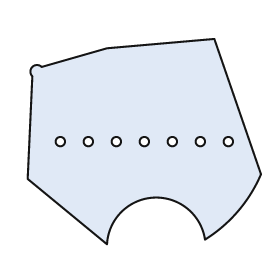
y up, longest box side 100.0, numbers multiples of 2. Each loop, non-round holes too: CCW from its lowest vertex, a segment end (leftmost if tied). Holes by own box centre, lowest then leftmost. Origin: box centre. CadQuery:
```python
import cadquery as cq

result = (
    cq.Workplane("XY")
    .moveTo(-16.0, -44.0)
    .threePointArc((4.0, -24.0), (26.0, -42.0))
    .threePointArc((40.0, -30.0), (50.0, -14.0))
    .lineTo(30.0, 44.0)
    .lineTo(-16.0, 40.0)
    .lineTo(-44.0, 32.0)
    .threePointArc((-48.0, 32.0), (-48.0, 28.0))
    .lineTo(-50.0, -16.0)
    .close()
    .moveTo(-36.0, 0.0)
    .circle(2.0)
    .moveTo(-24.0, 0.0)
    .circle(2.0)
    .moveTo(-12.0, 0.0)
    .circle(2.0)
    .moveTo(0.0, 0.0)
    .circle(2.0)
    .moveTo(12.0, 0.0)
    .circle(2.0)
    .moveTo(24.0, 0.0)
    .circle(2.0)
    .moveTo(36.0, 0.0)
    .circle(2.0)
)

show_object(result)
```